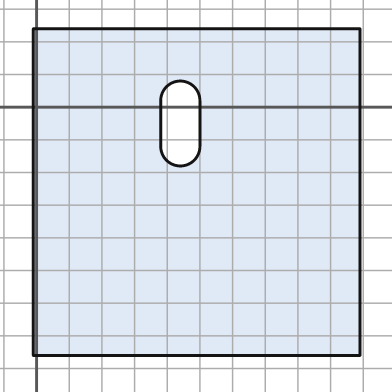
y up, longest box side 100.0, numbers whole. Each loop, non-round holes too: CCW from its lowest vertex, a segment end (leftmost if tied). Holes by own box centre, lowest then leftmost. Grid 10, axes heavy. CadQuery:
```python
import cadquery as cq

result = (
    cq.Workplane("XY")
    .moveTo(-1.0, -76.0)
    .lineTo(99.0, -76.0)
    .lineTo(99.0, 24.0)
    .lineTo(-1.0, 24.0)
    .close()
    .moveTo(38.0, -12.0)
    .threePointArc((44.0, -18.0), (50.0, -12.0))
    .lineTo(50.0, 2.0)
    .threePointArc((44.0, 8.0), (38.0, 2.0))
    .close()
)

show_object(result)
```